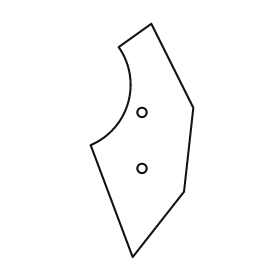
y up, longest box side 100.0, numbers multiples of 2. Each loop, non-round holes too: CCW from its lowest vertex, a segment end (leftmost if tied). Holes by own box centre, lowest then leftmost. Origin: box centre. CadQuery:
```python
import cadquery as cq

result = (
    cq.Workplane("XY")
    .moveTo(-4.0, -50.0)
    .lineTo(18.0, -22.0)
    .lineTo(22.0, 14.0)
    .lineTo(4.0, 50.0)
    .lineTo(-10.0, 40.0)
    .threePointArc((-6.0, 16.0), (-22.0, -2.0))
    .close()
    .moveTo(0.0, -12.0)
    .circle(2.0)
    .moveTo(0.0, 12.0)
    .circle(2.0)
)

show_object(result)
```